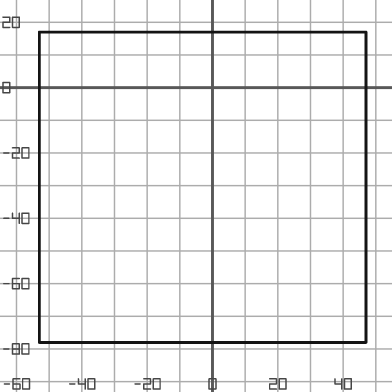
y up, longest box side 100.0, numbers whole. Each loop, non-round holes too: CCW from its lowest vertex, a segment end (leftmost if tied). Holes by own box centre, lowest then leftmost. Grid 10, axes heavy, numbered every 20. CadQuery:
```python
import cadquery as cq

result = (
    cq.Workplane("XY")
    .moveTo(-53.0, -78.0)
    .lineTo(47.0, -78.0)
    .lineTo(47.0, 17.0)
    .lineTo(-53.0, 17.0)
    .close()
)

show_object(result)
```